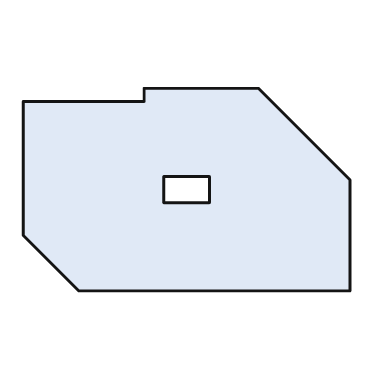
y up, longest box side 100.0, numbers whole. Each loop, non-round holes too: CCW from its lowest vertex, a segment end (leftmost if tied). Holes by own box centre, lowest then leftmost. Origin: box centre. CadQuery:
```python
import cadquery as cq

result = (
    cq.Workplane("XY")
    .moveTo(-33.0, -31.0)
    .lineTo(50.0, -31.0)
    .lineTo(50.0, 3.0)
    .lineTo(22.0, 31.0)
    .lineTo(-13.0, 31.0)
    .lineTo(-13.0, 27.0)
    .lineTo(-50.0, 27.0)
    .lineTo(-50.0, -14.0)
    .close()
    .moveTo(-7.0, -4.0)
    .lineTo(7.0, -4.0)
    .lineTo(7.0, 4.0)
    .lineTo(-7.0, 4.0)
    .close()
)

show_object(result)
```